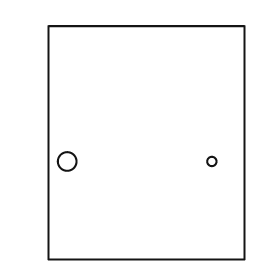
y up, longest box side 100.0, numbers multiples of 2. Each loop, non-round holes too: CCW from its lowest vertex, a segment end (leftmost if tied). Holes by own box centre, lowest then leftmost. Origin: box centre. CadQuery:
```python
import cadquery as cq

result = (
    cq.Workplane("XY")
    .moveTo(-42.0, -50.0)
    .lineTo(42.0, -50.0)
    .lineTo(42.0, 50.0)
    .lineTo(-42.0, 50.0)
    .close()
    .moveTo(-34.0, -8.0)
    .circle(4.0)
    .moveTo(28.0, -8.0)
    .circle(2.0)
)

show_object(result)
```